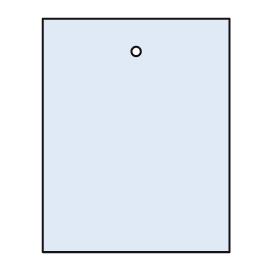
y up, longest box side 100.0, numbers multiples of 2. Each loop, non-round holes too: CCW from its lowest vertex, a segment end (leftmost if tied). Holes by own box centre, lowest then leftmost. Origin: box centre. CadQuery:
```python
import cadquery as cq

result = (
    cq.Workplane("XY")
    .moveTo(-40.0, -50.0)
    .lineTo(40.0, -50.0)
    .lineTo(40.0, 50.0)
    .lineTo(-40.0, 50.0)
    .close()
    .moveTo(0.0, 36.0)
    .circle(2.0)
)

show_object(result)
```